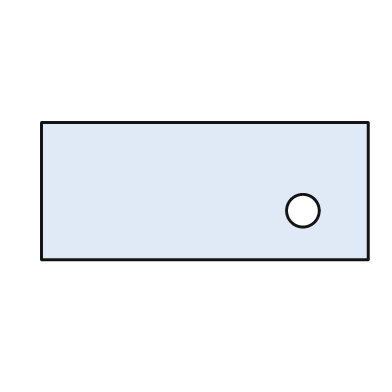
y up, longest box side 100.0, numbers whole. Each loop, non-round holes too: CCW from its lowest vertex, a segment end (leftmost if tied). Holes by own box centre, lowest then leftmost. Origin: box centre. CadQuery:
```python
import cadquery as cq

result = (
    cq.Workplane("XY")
    .moveTo(-50.0, -21.0)
    .lineTo(50.0, -21.0)
    .lineTo(50.0, 21.0)
    .lineTo(-50.0, 21.0)
    .close()
    .moveTo(30.0, -6.0)
    .circle(5.0)
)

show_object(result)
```